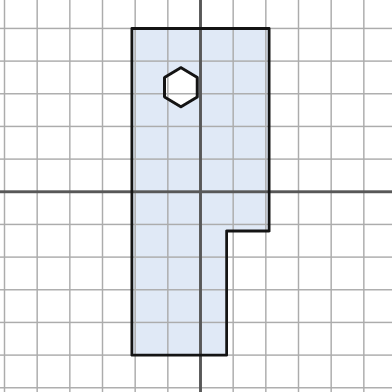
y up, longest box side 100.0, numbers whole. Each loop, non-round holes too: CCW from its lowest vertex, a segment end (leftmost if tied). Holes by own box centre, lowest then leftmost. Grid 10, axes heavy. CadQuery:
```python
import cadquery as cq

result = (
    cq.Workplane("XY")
    .moveTo(-21.0, -50.0)
    .lineTo(8.0, -50.0)
    .lineTo(8.0, -12.0)
    .lineTo(21.0, -12.0)
    .lineTo(21.0, 50.0)
    .lineTo(-21.0, 50.0)
    .close()
    .moveTo(-6.0, 26.0)
    .lineTo(-1.0, 29.0)
    .lineTo(-1.0, 35.0)
    .lineTo(-6.0, 38.0)
    .lineTo(-11.0, 35.0)
    .lineTo(-11.0, 29.0)
    .close()
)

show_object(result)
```